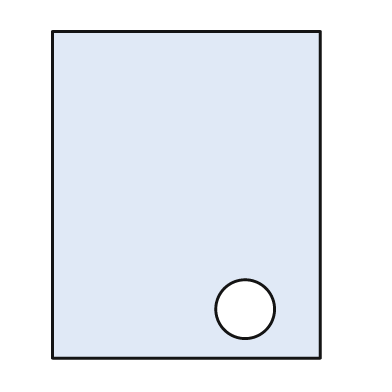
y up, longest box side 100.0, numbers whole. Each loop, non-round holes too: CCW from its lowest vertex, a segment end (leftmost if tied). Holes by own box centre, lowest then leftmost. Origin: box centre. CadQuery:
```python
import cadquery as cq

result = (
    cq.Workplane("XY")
    .moveTo(-41.0, -50.0)
    .lineTo(41.0, -50.0)
    .lineTo(41.0, 50.0)
    .lineTo(-41.0, 50.0)
    .close()
    .moveTo(18.0, -35.0)
    .circle(9.0)
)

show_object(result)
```